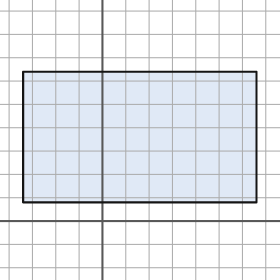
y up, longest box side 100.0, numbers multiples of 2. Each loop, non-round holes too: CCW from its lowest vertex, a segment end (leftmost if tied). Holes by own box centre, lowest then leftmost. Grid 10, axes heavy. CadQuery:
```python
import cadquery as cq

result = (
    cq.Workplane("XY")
    .moveTo(-34.0, 8.0)
    .lineTo(66.0, 8.0)
    .lineTo(66.0, 64.0)
    .lineTo(-34.0, 64.0)
    .close()
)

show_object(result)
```